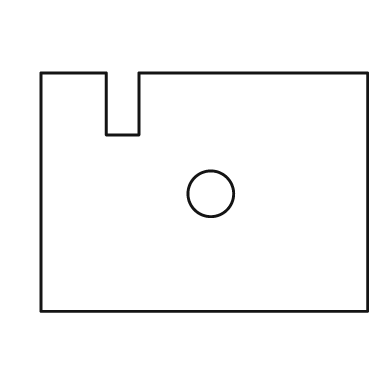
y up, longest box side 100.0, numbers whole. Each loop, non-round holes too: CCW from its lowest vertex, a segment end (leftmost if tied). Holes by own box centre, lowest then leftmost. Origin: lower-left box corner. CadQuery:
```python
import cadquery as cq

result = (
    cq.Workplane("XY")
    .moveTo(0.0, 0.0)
    .lineTo(100.0, 0.0)
    .lineTo(100.0, 73.0)
    .lineTo(30.0, 73.0)
    .lineTo(30.0, 54.0)
    .lineTo(20.0, 54.0)
    .lineTo(20.0, 73.0)
    .lineTo(0.0, 73.0)
    .close()
    .moveTo(52.0, 36.0)
    .circle(7.0)
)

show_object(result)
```